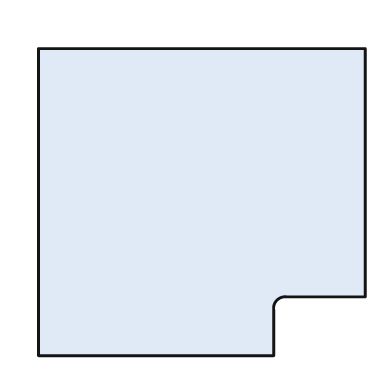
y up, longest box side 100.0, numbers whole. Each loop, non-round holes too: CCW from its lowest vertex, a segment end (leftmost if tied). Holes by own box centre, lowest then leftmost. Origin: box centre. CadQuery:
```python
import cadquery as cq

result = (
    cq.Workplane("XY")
    .moveTo(-50.0, -47.0)
    .lineTo(22.0, -47.0)
    .lineTo(22.0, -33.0)
    .threePointArc((23.0, -30.0), (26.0, -29.0))
    .lineTo(50.0, -29.0)
    .lineTo(50.0, 47.0)
    .lineTo(-50.0, 47.0)
    .close()
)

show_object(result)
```